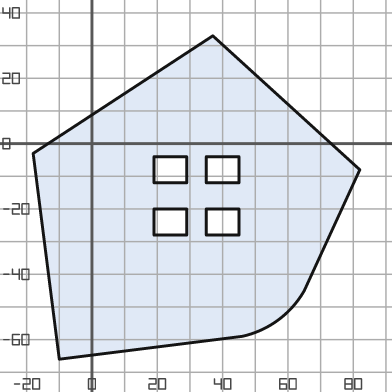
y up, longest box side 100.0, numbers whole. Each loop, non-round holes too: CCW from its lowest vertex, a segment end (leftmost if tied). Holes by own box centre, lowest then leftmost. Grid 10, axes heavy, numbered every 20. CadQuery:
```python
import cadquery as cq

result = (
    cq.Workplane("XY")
    .moveTo(-10.0, -66.0)
    .lineTo(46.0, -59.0)
    .threePointArc((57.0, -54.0), (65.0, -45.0))
    .lineTo(82.0, -8.0)
    .lineTo(37.0, 33.0)
    .lineTo(-18.0, -3.0)
    .close()
    .moveTo(19.0, -28.0)
    .lineTo(29.0, -28.0)
    .lineTo(29.0, -20.0)
    .lineTo(19.0, -20.0)
    .close()
    .moveTo(35.0, -28.0)
    .lineTo(45.0, -28.0)
    .lineTo(45.0, -20.0)
    .lineTo(35.0, -20.0)
    .close()
    .moveTo(19.0, -12.0)
    .lineTo(29.0, -12.0)
    .lineTo(29.0, -4.0)
    .lineTo(19.0, -4.0)
    .close()
    .moveTo(35.0, -12.0)
    .lineTo(45.0, -12.0)
    .lineTo(45.0, -4.0)
    .lineTo(35.0, -4.0)
    .close()
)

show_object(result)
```